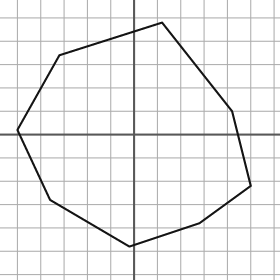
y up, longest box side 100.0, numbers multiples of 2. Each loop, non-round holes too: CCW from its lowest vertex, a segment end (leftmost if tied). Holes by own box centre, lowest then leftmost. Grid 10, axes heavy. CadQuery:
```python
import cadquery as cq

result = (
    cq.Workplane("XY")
    .moveTo(-2.0, -48.0)
    .lineTo(28.0, -38.0)
    .lineTo(50.0, -22.0)
    .lineTo(42.0, 10.0)
    .lineTo(12.0, 48.0)
    .lineTo(-32.0, 34.0)
    .lineTo(-50.0, 2.0)
    .lineTo(-36.0, -28.0)
    .close()
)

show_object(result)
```